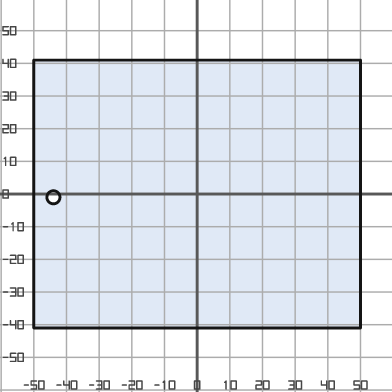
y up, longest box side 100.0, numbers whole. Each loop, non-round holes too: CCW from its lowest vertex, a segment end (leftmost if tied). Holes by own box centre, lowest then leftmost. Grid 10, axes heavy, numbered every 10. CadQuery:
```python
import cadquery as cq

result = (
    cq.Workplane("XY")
    .moveTo(-50.0, -41.0)
    .lineTo(50.0, -41.0)
    .lineTo(50.0, 41.0)
    .lineTo(-50.0, 41.0)
    .close()
    .moveTo(-44.0, -1.0)
    .circle(2.0)
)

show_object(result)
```